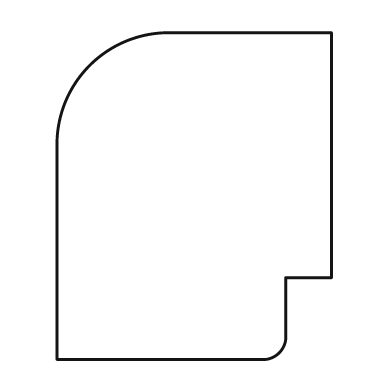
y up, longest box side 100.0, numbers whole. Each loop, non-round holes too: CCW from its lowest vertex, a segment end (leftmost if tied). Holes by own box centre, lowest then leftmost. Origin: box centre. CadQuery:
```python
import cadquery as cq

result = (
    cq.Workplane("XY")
    .moveTo(-42.0, -50.0)
    .lineTo(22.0, -50.0)
    .threePointArc((26.0, -48.0), (28.0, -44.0))
    .lineTo(28.0, -25.0)
    .lineTo(42.0, -25.0)
    .lineTo(42.0, 50.0)
    .lineTo(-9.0, 50.0)
    .threePointArc((-32.0, 40.0), (-42.0, 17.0))
    .close()
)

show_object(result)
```